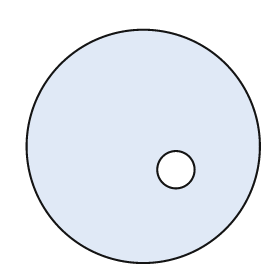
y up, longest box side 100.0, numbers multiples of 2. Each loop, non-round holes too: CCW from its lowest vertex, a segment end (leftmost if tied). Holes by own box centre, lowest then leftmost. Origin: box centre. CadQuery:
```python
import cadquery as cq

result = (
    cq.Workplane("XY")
    .moveTo(0.0, 0.0)
    .circle(50.0)
    .moveTo(14.0, -10.0)
    .circle(8.0)
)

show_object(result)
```